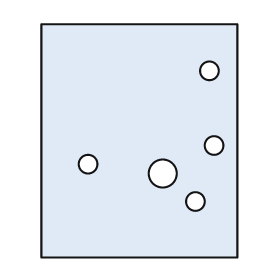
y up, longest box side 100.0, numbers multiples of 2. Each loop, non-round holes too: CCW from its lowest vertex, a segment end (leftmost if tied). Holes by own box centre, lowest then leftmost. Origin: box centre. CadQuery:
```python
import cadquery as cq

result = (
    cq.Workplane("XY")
    .moveTo(-42.0, -50.0)
    .lineTo(42.0, -50.0)
    .lineTo(42.0, 50.0)
    .lineTo(-42.0, 50.0)
    .close()
    .moveTo(24.0, -26.0)
    .circle(4.0)
    .moveTo(10.0, -14.0)
    .circle(6.0)
    .moveTo(-22.0, -10.0)
    .circle(4.0)
    .moveTo(32.0, -2.0)
    .circle(4.0)
    .moveTo(30.0, 30.0)
    .circle(4.0)
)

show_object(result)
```